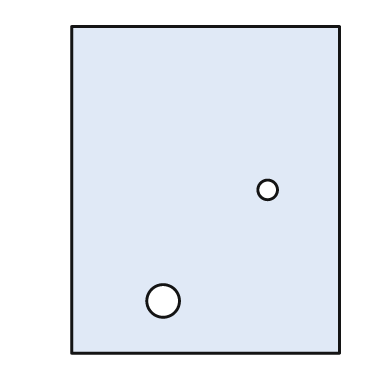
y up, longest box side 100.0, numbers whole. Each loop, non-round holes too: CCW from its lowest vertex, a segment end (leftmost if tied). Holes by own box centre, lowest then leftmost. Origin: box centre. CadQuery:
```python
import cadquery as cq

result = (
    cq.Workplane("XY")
    .moveTo(-41.0, -50.0)
    .lineTo(41.0, -50.0)
    .lineTo(41.0, 50.0)
    .lineTo(-41.0, 50.0)
    .close()
    .moveTo(-13.0, -34.0)
    .circle(5.0)
    .moveTo(19.0, 0.0)
    .circle(3.0)
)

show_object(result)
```